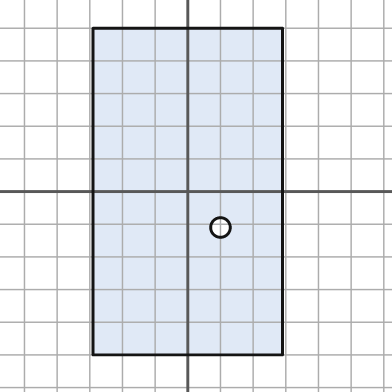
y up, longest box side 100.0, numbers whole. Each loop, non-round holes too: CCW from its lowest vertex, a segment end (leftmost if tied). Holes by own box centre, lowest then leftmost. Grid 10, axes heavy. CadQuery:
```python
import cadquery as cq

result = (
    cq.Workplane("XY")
    .moveTo(-29.0, -50.0)
    .lineTo(29.0, -50.0)
    .lineTo(29.0, 50.0)
    .lineTo(-29.0, 50.0)
    .close()
    .moveTo(10.0, -11.0)
    .circle(3.0)
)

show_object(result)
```